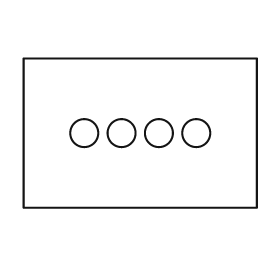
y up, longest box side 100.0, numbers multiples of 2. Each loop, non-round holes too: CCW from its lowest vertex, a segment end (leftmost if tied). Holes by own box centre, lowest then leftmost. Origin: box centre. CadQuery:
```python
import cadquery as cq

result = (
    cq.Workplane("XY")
    .moveTo(-50.0, -32.0)
    .lineTo(50.0, -32.0)
    .lineTo(50.0, 32.0)
    .lineTo(-50.0, 32.0)
    .close()
    .moveTo(-24.0, 0.0)
    .circle(6.0)
    .moveTo(-8.0, 0.0)
    .circle(6.0)
    .moveTo(8.0, 0.0)
    .circle(6.0)
    .moveTo(24.0, 0.0)
    .circle(6.0)
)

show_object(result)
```